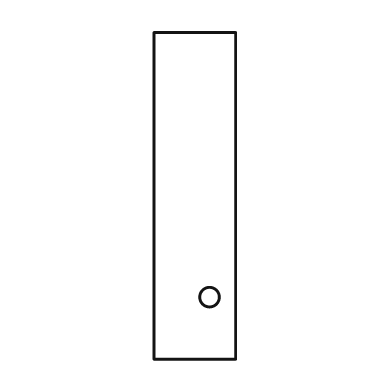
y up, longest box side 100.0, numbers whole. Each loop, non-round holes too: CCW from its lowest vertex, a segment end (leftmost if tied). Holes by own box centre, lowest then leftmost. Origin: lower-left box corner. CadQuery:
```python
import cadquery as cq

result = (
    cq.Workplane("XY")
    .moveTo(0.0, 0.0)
    .lineTo(25.0, 0.0)
    .lineTo(25.0, 100.0)
    .lineTo(0.0, 100.0)
    .close()
    .moveTo(17.0, 19.0)
    .circle(3.0)
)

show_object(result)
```